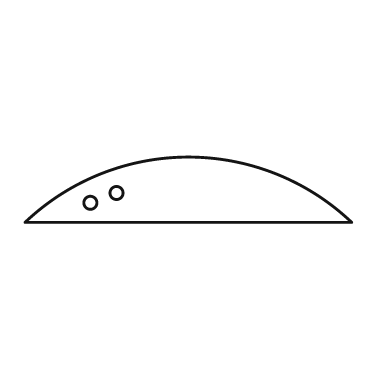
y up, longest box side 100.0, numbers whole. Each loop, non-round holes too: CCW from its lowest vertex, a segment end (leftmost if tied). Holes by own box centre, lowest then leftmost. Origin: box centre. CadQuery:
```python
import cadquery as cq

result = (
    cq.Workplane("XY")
    .moveTo(-50.0, -10.0)
    .lineTo(50.0, -10.0)
    .threePointArc((0.0, 10.0), (-50.0, -10.0))
    .close()
    .moveTo(-30.0, -4.0)
    .circle(2.0)
    .moveTo(-22.0, -1.0)
    .circle(2.0)
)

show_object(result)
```